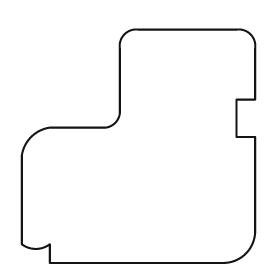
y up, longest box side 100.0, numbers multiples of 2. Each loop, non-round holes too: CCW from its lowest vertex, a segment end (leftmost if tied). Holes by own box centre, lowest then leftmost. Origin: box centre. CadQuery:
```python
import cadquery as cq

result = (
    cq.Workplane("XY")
    .moveTo(-38.0, -50.0)
    .lineTo(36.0, -50.0)
    .threePointArc((46.0, -46.0), (50.0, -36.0))
    .lineTo(50.0, 4.0)
    .lineTo(42.0, 4.0)
    .lineTo(42.0, 20.0)
    .lineTo(50.0, 20.0)
    .lineTo(50.0, 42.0)
    .threePointArc((48.0, 48.0), (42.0, 50.0))
    .lineTo(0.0, 50.0)
    .threePointArc((-6.0, 48.0), (-8.0, 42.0))
    .lineTo(-8.0, 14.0)
    .threePointArc((-10.0, 10.0), (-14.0, 8.0))
    .lineTo(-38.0, 8.0)
    .threePointArc((-46.0, 4.0), (-50.0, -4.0))
    .lineTo(-50.0, -42.0)
    .threePointArc((-44.0, -44.0), (-38.0, -42.0))
    .close()
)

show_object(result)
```